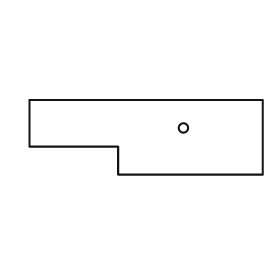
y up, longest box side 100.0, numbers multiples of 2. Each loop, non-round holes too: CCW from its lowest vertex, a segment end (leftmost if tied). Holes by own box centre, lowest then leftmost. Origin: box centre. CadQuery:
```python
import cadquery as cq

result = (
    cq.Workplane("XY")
    .moveTo(-12.0, -16.0)
    .lineTo(50.0, -16.0)
    .lineTo(50.0, 16.0)
    .lineTo(-50.0, 16.0)
    .lineTo(-50.0, -4.0)
    .lineTo(-12.0, -4.0)
    .close()
    .moveTo(16.0, 4.0)
    .circle(2.0)
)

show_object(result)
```